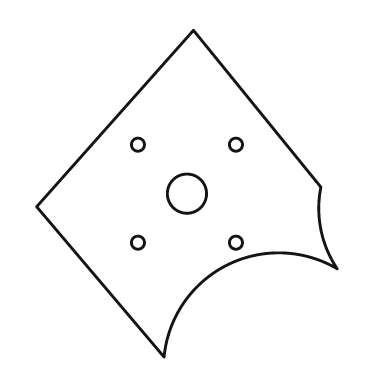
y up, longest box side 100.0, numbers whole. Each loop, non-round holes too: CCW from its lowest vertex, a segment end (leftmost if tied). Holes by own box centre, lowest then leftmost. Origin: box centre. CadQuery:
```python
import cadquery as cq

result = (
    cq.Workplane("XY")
    .moveTo(-7.0, -50.0)
    .threePointArc((12.0, -22.0), (46.0, -23.0))
    .threePointArc((41.0, -11.0), (41.0, 2.0))
    .lineTo(2.0, 50.0)
    .lineTo(-46.0, -4.0)
    .close()
    .moveTo(-15.0, -15.0)
    .circle(2.0)
    .moveTo(15.0, -15.0)
    .circle(2.0)
    .moveTo(0.0, 0.0)
    .circle(6.0)
    .moveTo(-15.0, 15.0)
    .circle(2.0)
    .moveTo(15.0, 15.0)
    .circle(2.0)
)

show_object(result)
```